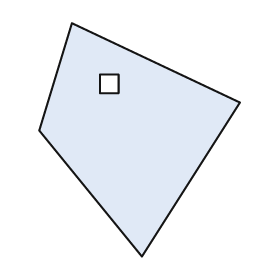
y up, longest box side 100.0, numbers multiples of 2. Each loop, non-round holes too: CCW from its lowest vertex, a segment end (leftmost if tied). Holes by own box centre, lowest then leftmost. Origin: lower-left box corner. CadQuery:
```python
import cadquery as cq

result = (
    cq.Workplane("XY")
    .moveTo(44.0, 0.0)
    .lineTo(86.0, 66.0)
    .lineTo(14.0, 100.0)
    .lineTo(0.0, 54.0)
    .close()
    .moveTo(26.0, 70.0)
    .lineTo(34.0, 70.0)
    .lineTo(34.0, 78.0)
    .lineTo(26.0, 78.0)
    .close()
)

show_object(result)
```